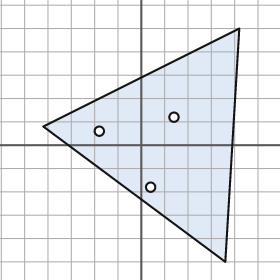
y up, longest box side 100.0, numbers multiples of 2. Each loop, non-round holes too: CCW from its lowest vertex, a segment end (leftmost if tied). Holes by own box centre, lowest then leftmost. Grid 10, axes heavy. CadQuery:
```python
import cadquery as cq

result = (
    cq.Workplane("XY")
    .moveTo(36.0, -50.0)
    .lineTo(42.0, 50.0)
    .lineTo(-42.0, 8.0)
    .close()
    .moveTo(4.0, -18.0)
    .circle(2.0)
    .moveTo(-18.0, 6.0)
    .circle(2.0)
    .moveTo(14.0, 12.0)
    .circle(2.0)
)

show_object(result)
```